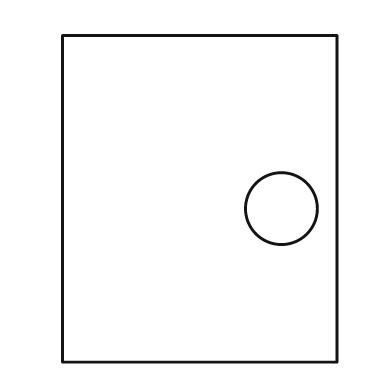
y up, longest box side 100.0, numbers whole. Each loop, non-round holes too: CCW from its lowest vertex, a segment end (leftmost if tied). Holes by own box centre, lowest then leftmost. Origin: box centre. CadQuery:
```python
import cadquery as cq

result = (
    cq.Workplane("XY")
    .moveTo(-42.0, -50.0)
    .lineTo(42.0, -50.0)
    .lineTo(42.0, 50.0)
    .lineTo(-42.0, 50.0)
    .close()
    .moveTo(25.0, -3.0)
    .circle(11.0)
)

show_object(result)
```